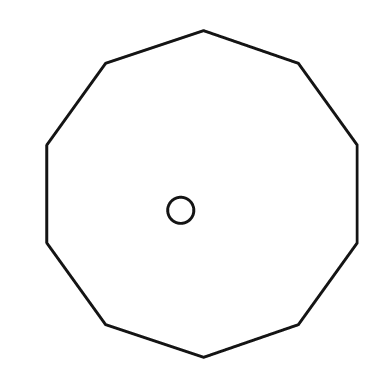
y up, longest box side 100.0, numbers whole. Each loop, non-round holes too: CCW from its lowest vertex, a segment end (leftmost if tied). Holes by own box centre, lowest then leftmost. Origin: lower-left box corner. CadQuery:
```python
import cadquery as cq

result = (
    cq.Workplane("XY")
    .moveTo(48.0, 0.0)
    .lineTo(77.0, 10.0)
    .lineTo(95.0, 35.0)
    .lineTo(95.0, 65.0)
    .lineTo(77.0, 90.0)
    .lineTo(48.0, 100.0)
    .lineTo(18.0, 90.0)
    .lineTo(0.0, 65.0)
    .lineTo(0.0, 35.0)
    .lineTo(18.0, 10.0)
    .close()
    .moveTo(41.0, 45.0)
    .circle(4.0)
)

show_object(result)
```